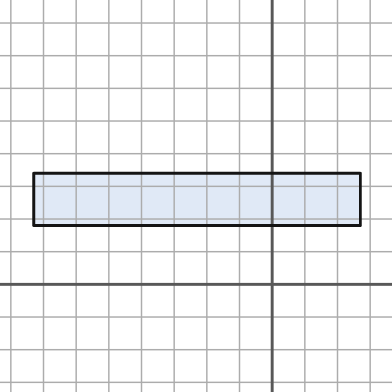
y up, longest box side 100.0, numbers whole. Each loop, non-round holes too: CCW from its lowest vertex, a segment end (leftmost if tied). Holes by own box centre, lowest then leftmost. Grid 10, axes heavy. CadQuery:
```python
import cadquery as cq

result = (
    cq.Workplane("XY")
    .moveTo(-73.0, 18.0)
    .lineTo(27.0, 18.0)
    .lineTo(27.0, 34.0)
    .lineTo(-73.0, 34.0)
    .close()
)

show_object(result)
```